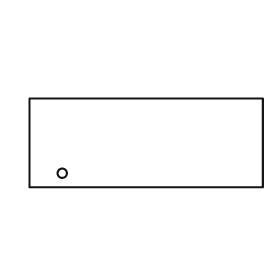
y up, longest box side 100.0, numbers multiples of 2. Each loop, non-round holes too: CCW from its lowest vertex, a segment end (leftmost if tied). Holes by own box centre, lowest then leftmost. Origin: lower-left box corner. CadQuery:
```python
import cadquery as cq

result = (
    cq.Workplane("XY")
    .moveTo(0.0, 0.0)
    .lineTo(100.0, 0.0)
    .lineTo(100.0, 38.0)
    .lineTo(0.0, 38.0)
    .close()
    .moveTo(14.0, 6.0)
    .circle(2.0)
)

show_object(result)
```